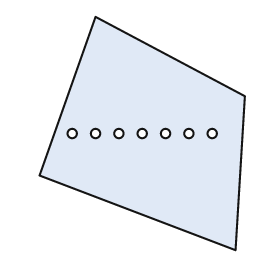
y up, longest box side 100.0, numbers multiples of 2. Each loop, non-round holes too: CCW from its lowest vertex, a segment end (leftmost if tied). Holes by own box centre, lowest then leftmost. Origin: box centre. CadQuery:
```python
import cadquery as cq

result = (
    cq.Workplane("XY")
    .moveTo(40.0, -50.0)
    .lineTo(44.0, 16.0)
    .lineTo(-20.0, 50.0)
    .lineTo(-44.0, -18.0)
    .close()
    .moveTo(-30.0, 0.0)
    .circle(2.0)
    .moveTo(-20.0, 0.0)
    .circle(2.0)
    .moveTo(-10.0, 0.0)
    .circle(2.0)
    .moveTo(0.0, 0.0)
    .circle(2.0)
    .moveTo(10.0, 0.0)
    .circle(2.0)
    .moveTo(20.0, 0.0)
    .circle(2.0)
    .moveTo(30.0, 0.0)
    .circle(2.0)
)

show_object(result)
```